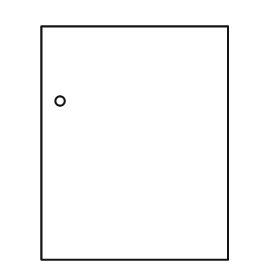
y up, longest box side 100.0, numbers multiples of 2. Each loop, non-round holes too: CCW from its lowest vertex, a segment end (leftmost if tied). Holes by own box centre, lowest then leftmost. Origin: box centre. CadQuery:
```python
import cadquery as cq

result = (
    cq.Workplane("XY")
    .moveTo(-40.0, -50.0)
    .lineTo(40.0, -50.0)
    .lineTo(40.0, 50.0)
    .lineTo(-40.0, 50.0)
    .close()
    .moveTo(-32.0, 18.0)
    .circle(2.0)
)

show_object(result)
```